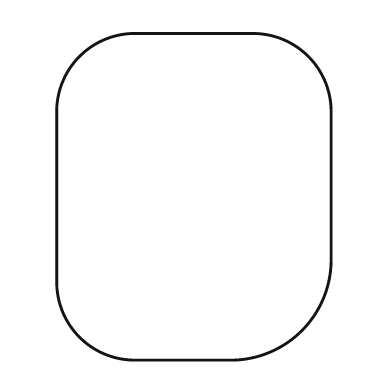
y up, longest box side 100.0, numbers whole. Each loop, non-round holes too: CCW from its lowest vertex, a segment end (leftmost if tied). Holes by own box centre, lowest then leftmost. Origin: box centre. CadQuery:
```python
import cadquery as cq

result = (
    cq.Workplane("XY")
    .moveTo(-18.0, -50.0)
    .lineTo(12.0, -50.0)
    .threePointArc((33.0, -41.0), (42.0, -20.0))
    .lineTo(42.0, 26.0)
    .threePointArc((35.0, 43.0), (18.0, 50.0))
    .lineTo(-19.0, 50.0)
    .threePointArc((-35.0, 43.0), (-42.0, 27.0))
    .lineTo(-42.0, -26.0)
    .threePointArc((-35.0, -43.0), (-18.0, -50.0))
    .close()
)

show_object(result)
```